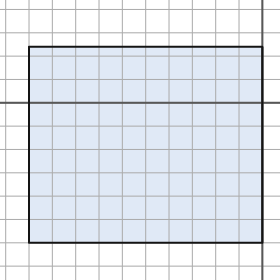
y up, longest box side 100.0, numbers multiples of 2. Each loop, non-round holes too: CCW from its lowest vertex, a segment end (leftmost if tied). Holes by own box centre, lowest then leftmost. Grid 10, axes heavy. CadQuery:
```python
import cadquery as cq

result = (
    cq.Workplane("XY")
    .moveTo(-100.0, -60.0)
    .lineTo(0.0, -60.0)
    .lineTo(0.0, 24.0)
    .lineTo(-100.0, 24.0)
    .close()
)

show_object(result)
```